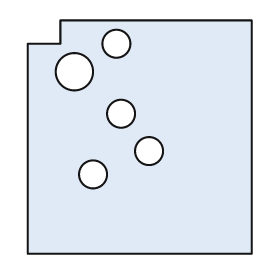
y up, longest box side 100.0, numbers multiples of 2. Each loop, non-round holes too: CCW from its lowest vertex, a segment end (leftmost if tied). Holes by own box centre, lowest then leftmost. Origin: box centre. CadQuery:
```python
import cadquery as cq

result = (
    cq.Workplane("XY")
    .moveTo(-48.0, -50.0)
    .lineTo(48.0, -50.0)
    .lineTo(48.0, 50.0)
    .lineTo(-34.0, 50.0)
    .lineTo(-34.0, 40.0)
    .lineTo(-48.0, 40.0)
    .close()
    .moveTo(-20.0, -16.0)
    .circle(6.0)
    .moveTo(4.0, -6.0)
    .circle(6.0)
    .moveTo(-8.0, 10.0)
    .circle(6.0)
    .moveTo(-28.0, 28.0)
    .circle(8.0)
    .moveTo(-10.0, 40.0)
    .circle(6.0)
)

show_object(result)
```